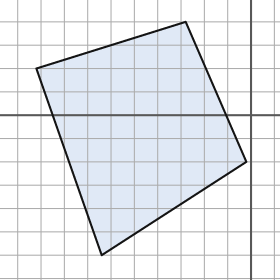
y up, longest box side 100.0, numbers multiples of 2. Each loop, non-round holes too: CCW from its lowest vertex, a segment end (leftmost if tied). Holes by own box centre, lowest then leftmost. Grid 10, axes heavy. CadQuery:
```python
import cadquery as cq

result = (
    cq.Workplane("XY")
    .moveTo(-64.0, -60.0)
    .lineTo(-2.0, -20.0)
    .lineTo(-28.0, 40.0)
    .lineTo(-92.0, 20.0)
    .close()
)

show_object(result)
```